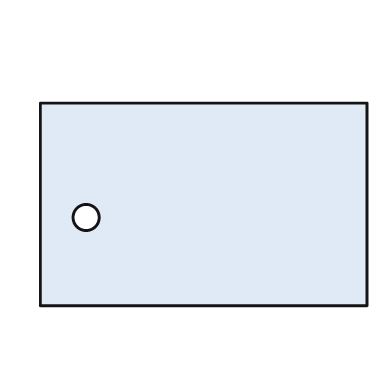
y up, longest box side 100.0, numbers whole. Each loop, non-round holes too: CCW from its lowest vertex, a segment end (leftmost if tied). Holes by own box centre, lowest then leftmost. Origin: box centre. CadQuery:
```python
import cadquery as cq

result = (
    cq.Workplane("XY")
    .moveTo(-50.0, -31.0)
    .lineTo(50.0, -31.0)
    .lineTo(50.0, 31.0)
    .lineTo(-50.0, 31.0)
    .close()
    .moveTo(-36.0, -4.0)
    .circle(4.0)
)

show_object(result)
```